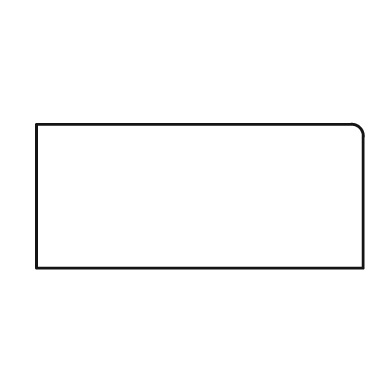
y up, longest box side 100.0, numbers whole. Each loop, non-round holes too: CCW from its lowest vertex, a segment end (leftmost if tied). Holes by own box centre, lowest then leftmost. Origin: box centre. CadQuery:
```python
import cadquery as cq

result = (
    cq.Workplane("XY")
    .moveTo(-50.0, -22.0)
    .lineTo(50.0, -22.0)
    .lineTo(50.0, 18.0)
    .threePointArc((49.0, 21.0), (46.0, 22.0))
    .lineTo(-50.0, 22.0)
    .close()
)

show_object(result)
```